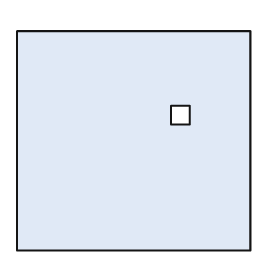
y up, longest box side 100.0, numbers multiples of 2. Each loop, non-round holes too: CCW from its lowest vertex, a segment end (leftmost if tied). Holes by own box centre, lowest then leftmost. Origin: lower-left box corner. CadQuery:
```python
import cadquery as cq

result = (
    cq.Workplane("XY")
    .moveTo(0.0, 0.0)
    .lineTo(100.0, 0.0)
    .lineTo(100.0, 94.0)
    .lineTo(0.0, 94.0)
    .close()
    .moveTo(66.0, 54.0)
    .lineTo(74.0, 54.0)
    .lineTo(74.0, 62.0)
    .lineTo(66.0, 62.0)
    .close()
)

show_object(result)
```